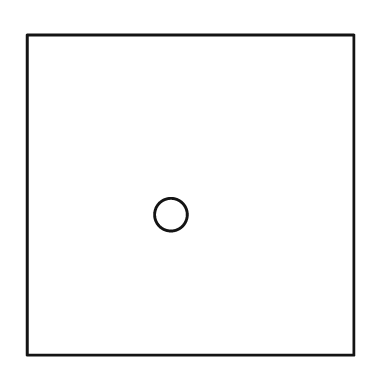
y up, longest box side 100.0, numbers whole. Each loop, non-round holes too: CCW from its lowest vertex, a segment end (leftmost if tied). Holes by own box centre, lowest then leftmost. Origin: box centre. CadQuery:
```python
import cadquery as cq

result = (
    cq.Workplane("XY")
    .moveTo(-50.0, -49.0)
    .lineTo(50.0, -49.0)
    .lineTo(50.0, 49.0)
    .lineTo(-50.0, 49.0)
    .close()
    .moveTo(-6.0, -6.0)
    .circle(5.0)
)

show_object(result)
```